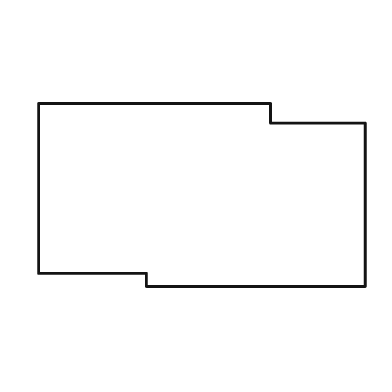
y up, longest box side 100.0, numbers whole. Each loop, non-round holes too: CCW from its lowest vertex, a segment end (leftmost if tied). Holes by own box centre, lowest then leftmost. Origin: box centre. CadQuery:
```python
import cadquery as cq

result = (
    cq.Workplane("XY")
    .moveTo(-17.0, -28.0)
    .lineTo(50.0, -28.0)
    .lineTo(50.0, 22.0)
    .lineTo(21.0, 22.0)
    .lineTo(21.0, 28.0)
    .lineTo(-50.0, 28.0)
    .lineTo(-50.0, -24.0)
    .lineTo(-17.0, -24.0)
    .close()
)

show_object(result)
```